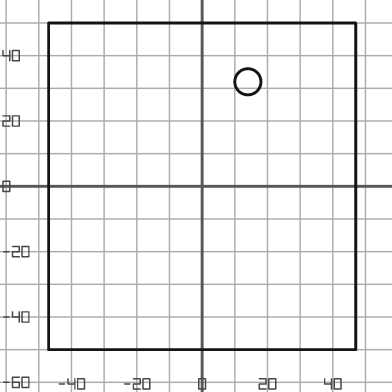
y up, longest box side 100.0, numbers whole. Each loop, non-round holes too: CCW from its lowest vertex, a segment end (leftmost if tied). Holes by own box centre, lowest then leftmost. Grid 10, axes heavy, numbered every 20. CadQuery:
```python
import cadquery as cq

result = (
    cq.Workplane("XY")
    .moveTo(-47.0, -50.0)
    .lineTo(47.0, -50.0)
    .lineTo(47.0, 50.0)
    .lineTo(-47.0, 50.0)
    .close()
    .moveTo(14.0, 32.0)
    .circle(4.0)
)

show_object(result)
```